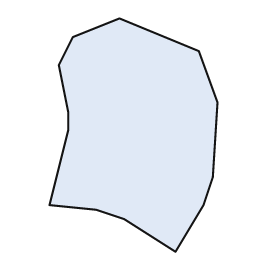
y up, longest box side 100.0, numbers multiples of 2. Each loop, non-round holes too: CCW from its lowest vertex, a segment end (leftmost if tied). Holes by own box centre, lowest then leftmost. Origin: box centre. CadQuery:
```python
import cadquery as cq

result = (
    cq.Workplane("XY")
    .moveTo(18.0, -50.0)
    .lineTo(30.0, -30.0)
    .lineTo(34.0, -18.0)
    .lineTo(36.0, 14.0)
    .lineTo(28.0, 36.0)
    .lineTo(-6.0, 50.0)
    .lineTo(-26.0, 42.0)
    .lineTo(-32.0, 30.0)
    .lineTo(-28.0, 10.0)
    .lineTo(-28.0, 2.0)
    .lineTo(-36.0, -30.0)
    .lineTo(-16.0, -32.0)
    .lineTo(-4.0, -36.0)
    .close()
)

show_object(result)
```